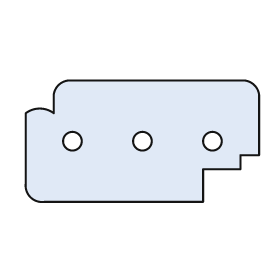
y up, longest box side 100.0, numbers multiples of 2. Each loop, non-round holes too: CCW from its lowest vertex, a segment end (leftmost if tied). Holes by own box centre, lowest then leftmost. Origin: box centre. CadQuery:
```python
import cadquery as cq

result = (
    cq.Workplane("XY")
    .moveTo(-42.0, -26.0)
    .lineTo(26.0, -26.0)
    .lineTo(26.0, -12.0)
    .lineTo(42.0, -12.0)
    .lineTo(42.0, -6.0)
    .lineTo(50.0, -6.0)
    .lineTo(50.0, 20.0)
    .threePointArc((48.0, 24.0), (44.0, 26.0))
    .lineTo(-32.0, 26.0)
    .threePointArc((-36.0, 24.0), (-38.0, 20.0))
    .lineTo(-38.0, 12.0)
    .threePointArc((-44.0, 14.0), (-50.0, 12.0))
    .lineTo(-50.0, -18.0)
    .threePointArc((-48.0, -24.0), (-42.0, -26.0))
    .close()
    .moveTo(-30.0, 0.0)
    .circle(4.0)
    .moveTo(0.0, 0.0)
    .circle(4.0)
    .moveTo(30.0, 0.0)
    .circle(4.0)
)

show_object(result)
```